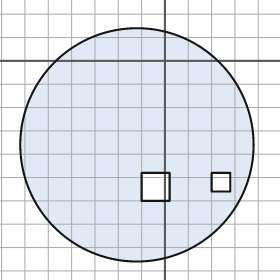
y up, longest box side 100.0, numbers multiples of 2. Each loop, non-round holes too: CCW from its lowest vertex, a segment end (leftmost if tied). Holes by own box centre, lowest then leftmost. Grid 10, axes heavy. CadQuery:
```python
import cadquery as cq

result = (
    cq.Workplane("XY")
    .moveTo(-12.0, -36.0)
    .circle(50.0)
    .moveTo(-10.0, -60.0)
    .lineTo(2.0, -60.0)
    .lineTo(2.0, -48.0)
    .lineTo(-10.0, -48.0)
    .close()
    .moveTo(20.0, -56.0)
    .lineTo(28.0, -56.0)
    .lineTo(28.0, -48.0)
    .lineTo(20.0, -48.0)
    .close()
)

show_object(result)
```